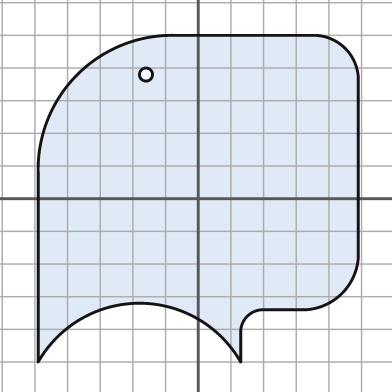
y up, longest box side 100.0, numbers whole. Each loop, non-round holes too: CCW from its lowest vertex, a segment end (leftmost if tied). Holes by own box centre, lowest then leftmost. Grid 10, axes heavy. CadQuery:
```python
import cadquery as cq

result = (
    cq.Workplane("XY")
    .moveTo(-49.0, -50.0)
    .threePointArc((-18.0, -32.0), (13.0, -50.0))
    .lineTo(13.0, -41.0)
    .threePointArc((15.0, -36.0), (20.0, -34.0))
    .lineTo(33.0, -34.0)
    .threePointArc((44.0, -29.0), (49.0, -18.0))
    .lineTo(49.0, 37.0)
    .threePointArc((45.0, 46.0), (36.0, 50.0))
    .lineTo(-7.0, 50.0)
    .threePointArc((-37.0, 38.0), (-49.0, 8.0))
    .close()
    .moveTo(-16.0, 38.0)
    .circle(2.0)
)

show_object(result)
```